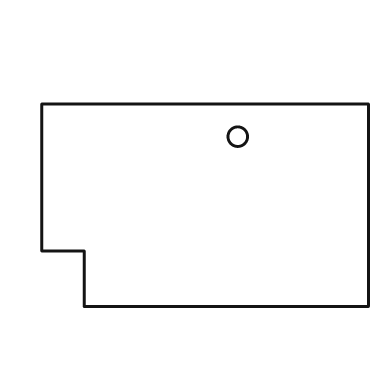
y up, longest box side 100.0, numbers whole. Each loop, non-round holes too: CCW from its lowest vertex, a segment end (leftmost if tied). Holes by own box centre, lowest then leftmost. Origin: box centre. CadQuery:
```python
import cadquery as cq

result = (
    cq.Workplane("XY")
    .moveTo(-37.0, -31.0)
    .lineTo(50.0, -31.0)
    .lineTo(50.0, 31.0)
    .lineTo(-50.0, 31.0)
    .lineTo(-50.0, -14.0)
    .lineTo(-37.0, -14.0)
    .close()
    .moveTo(10.0, 21.0)
    .circle(3.0)
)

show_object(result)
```